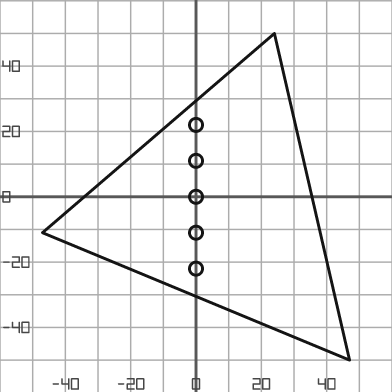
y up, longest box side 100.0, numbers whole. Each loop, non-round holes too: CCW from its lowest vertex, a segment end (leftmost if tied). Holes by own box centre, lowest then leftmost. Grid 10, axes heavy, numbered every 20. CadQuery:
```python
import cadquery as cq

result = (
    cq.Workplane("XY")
    .moveTo(47.0, -50.0)
    .lineTo(24.0, 50.0)
    .lineTo(-47.0, -11.0)
    .close()
    .moveTo(0.0, -22.0)
    .circle(2.0)
    .moveTo(0.0, -11.0)
    .circle(2.0)
    .moveTo(0.0, 0.0)
    .circle(2.0)
    .moveTo(0.0, 11.0)
    .circle(2.0)
    .moveTo(0.0, 22.0)
    .circle(2.0)
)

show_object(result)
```